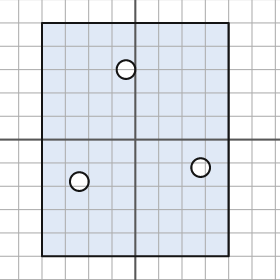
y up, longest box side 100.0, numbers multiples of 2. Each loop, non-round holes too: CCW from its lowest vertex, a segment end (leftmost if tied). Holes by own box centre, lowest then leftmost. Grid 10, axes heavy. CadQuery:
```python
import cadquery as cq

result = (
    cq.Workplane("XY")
    .moveTo(-40.0, -50.0)
    .lineTo(40.0, -50.0)
    .lineTo(40.0, 50.0)
    .lineTo(-40.0, 50.0)
    .close()
    .moveTo(-24.0, -18.0)
    .circle(4.0)
    .moveTo(28.0, -12.0)
    .circle(4.0)
    .moveTo(-4.0, 30.0)
    .circle(4.0)
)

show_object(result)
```